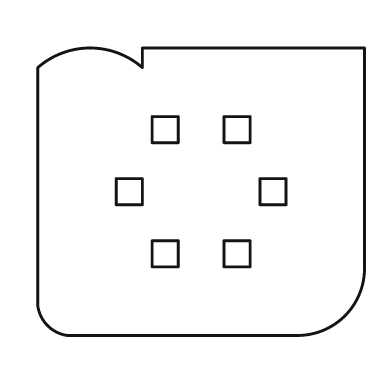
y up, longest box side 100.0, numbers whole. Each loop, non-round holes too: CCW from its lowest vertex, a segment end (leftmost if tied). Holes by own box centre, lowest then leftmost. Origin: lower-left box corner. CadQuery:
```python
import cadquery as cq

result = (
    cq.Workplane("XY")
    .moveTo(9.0, 0.0)
    .lineTo(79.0, 0.0)
    .threePointArc((94.0, 6.0), (100.0, 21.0))
    .lineTo(100.0, 88.0)
    .lineTo(32.0, 88.0)
    .lineTo(32.0, 82.0)
    .threePointArc((16.0, 88.0), (0.0, 82.0))
    .lineTo(0.0, 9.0)
    .threePointArc((3.0, 3.0), (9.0, 0.0))
    .close()
    .moveTo(35.0, 21.0)
    .lineTo(43.0, 21.0)
    .lineTo(43.0, 29.0)
    .lineTo(35.0, 29.0)
    .close()
    .moveTo(57.0, 21.0)
    .lineTo(65.0, 21.0)
    .lineTo(65.0, 29.0)
    .lineTo(57.0, 29.0)
    .close()
    .moveTo(24.0, 40.0)
    .lineTo(32.0, 40.0)
    .lineTo(32.0, 48.0)
    .lineTo(24.0, 48.0)
    .close()
    .moveTo(68.0, 40.0)
    .lineTo(76.0, 40.0)
    .lineTo(76.0, 48.0)
    .lineTo(68.0, 48.0)
    .close()
    .moveTo(35.0, 59.0)
    .lineTo(43.0, 59.0)
    .lineTo(43.0, 67.0)
    .lineTo(35.0, 67.0)
    .close()
    .moveTo(57.0, 59.0)
    .lineTo(65.0, 59.0)
    .lineTo(65.0, 67.0)
    .lineTo(57.0, 67.0)
    .close()
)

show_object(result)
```